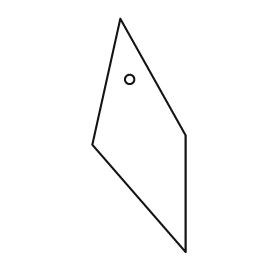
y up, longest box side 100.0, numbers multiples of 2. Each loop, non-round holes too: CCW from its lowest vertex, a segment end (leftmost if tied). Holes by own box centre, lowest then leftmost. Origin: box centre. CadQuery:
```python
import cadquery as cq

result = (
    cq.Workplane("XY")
    .moveTo(20.0, -50.0)
    .lineTo(20.0, 0.0)
    .lineTo(-8.0, 50.0)
    .lineTo(-20.0, -4.0)
    .close()
    .moveTo(-4.0, 24.0)
    .circle(2.0)
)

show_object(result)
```